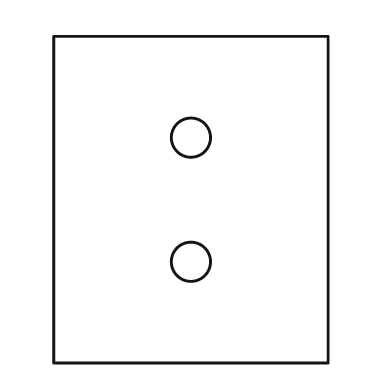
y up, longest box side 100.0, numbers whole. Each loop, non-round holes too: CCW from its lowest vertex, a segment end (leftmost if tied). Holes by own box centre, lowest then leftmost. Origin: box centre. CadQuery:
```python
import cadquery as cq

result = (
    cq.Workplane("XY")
    .moveTo(-42.0, -50.0)
    .lineTo(42.0, -50.0)
    .lineTo(42.0, 50.0)
    .lineTo(-42.0, 50.0)
    .close()
    .moveTo(0.0, -19.0)
    .circle(6.0)
    .moveTo(0.0, 19.0)
    .circle(6.0)
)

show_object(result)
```